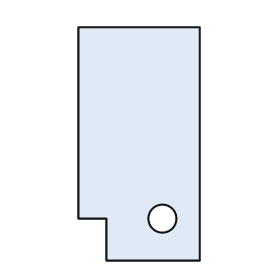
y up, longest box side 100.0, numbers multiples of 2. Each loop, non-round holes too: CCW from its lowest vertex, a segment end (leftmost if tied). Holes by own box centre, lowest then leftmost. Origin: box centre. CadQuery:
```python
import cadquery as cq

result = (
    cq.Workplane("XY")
    .moveTo(-14.0, -50.0)
    .lineTo(26.0, -50.0)
    .lineTo(26.0, 50.0)
    .lineTo(-26.0, 50.0)
    .lineTo(-26.0, -32.0)
    .lineTo(-14.0, -32.0)
    .close()
    .moveTo(10.0, -32.0)
    .circle(6.0)
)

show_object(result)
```